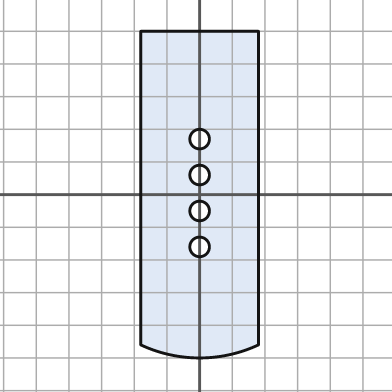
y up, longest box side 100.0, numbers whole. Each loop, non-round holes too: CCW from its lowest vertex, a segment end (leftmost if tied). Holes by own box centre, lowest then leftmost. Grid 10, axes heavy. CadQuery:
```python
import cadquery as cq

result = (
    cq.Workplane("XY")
    .moveTo(-18.0, -46.0)
    .threePointArc((0.0, -50.0), (18.0, -46.0))
    .lineTo(18.0, 50.0)
    .lineTo(-18.0, 50.0)
    .close()
    .moveTo(0.0, -16.0)
    .circle(3.0)
    .moveTo(0.0, -5.0)
    .circle(3.0)
    .moveTo(0.0, 6.0)
    .circle(3.0)
    .moveTo(0.0, 17.0)
    .circle(3.0)
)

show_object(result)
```